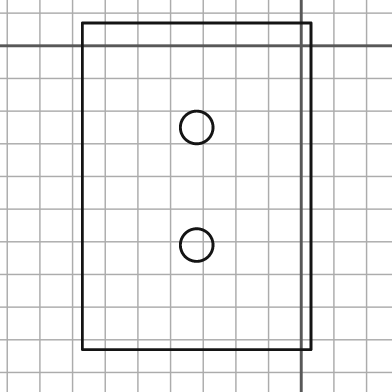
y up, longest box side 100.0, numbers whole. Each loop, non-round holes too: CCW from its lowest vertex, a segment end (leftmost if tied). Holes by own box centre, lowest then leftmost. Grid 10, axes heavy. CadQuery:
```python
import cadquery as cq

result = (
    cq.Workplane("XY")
    .moveTo(-67.0, -93.0)
    .lineTo(3.0, -93.0)
    .lineTo(3.0, 7.0)
    .lineTo(-67.0, 7.0)
    .close()
    .moveTo(-32.0, -61.0)
    .circle(5.0)
    .moveTo(-32.0, -25.0)
    .circle(5.0)
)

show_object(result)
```